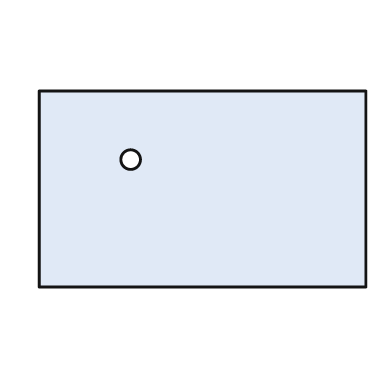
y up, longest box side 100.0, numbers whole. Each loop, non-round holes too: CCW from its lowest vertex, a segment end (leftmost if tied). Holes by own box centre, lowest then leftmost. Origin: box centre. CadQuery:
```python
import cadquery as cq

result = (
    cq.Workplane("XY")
    .moveTo(-50.0, -30.0)
    .lineTo(50.0, -30.0)
    .lineTo(50.0, 30.0)
    .lineTo(-50.0, 30.0)
    .close()
    .moveTo(-22.0, 9.0)
    .circle(3.0)
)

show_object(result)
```